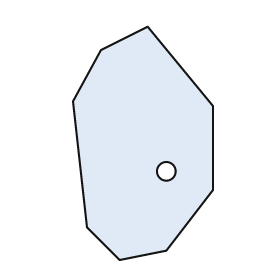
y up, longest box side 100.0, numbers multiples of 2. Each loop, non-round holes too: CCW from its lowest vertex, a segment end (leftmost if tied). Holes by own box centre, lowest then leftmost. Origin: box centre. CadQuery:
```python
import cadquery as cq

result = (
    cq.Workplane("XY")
    .moveTo(-10.0, -50.0)
    .lineTo(10.0, -46.0)
    .lineTo(30.0, -20.0)
    .lineTo(30.0, 16.0)
    .lineTo(2.0, 50.0)
    .lineTo(-18.0, 40.0)
    .lineTo(-30.0, 18.0)
    .lineTo(-24.0, -36.0)
    .close()
    .moveTo(10.0, -12.0)
    .circle(4.0)
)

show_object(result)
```